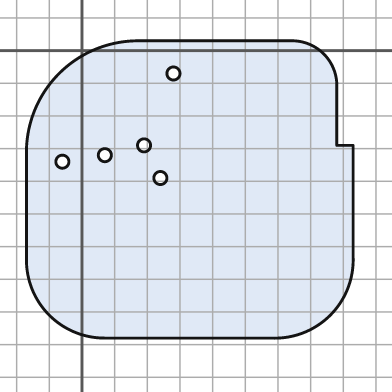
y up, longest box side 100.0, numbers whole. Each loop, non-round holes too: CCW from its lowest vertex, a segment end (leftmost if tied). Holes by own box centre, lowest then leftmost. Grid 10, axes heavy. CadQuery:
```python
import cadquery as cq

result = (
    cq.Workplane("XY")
    .moveTo(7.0, -88.0)
    .lineTo(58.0, -88.0)
    .threePointArc((76.0, -81.0), (83.0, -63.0))
    .lineTo(83.0, -29.0)
    .lineTo(78.0, -29.0)
    .lineTo(78.0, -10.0)
    .threePointArc((74.0, -1.0), (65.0, 3.0))
    .lineTo(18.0, 3.0)
    .threePointArc((-7.0, -7.0), (-17.0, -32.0))
    .lineTo(-17.0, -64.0)
    .threePointArc((-10.0, -81.0), (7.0, -88.0))
    .close()
    .moveTo(24.0, -39.0)
    .circle(2.0)
    .moveTo(-6.0, -34.0)
    .circle(2.0)
    .moveTo(7.0, -32.0)
    .circle(2.0)
    .moveTo(19.0, -29.0)
    .circle(2.0)
    .moveTo(28.0, -7.0)
    .circle(2.0)
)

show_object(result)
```